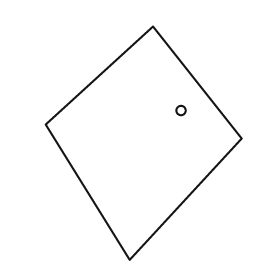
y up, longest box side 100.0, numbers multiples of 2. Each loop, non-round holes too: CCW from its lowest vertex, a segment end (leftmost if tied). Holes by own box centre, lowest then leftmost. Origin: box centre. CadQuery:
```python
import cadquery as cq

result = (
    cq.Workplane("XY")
    .moveTo(-6.0, -50.0)
    .lineTo(42.0, 2.0)
    .lineTo(4.0, 50.0)
    .lineTo(-42.0, 8.0)
    .close()
    .moveTo(16.0, 14.0)
    .circle(2.0)
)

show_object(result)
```